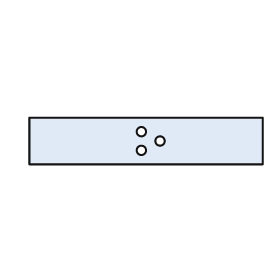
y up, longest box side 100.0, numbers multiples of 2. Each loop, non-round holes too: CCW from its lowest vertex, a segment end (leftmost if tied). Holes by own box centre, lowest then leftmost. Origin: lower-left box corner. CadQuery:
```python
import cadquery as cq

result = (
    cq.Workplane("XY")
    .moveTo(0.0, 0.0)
    .lineTo(100.0, 0.0)
    .lineTo(100.0, 20.0)
    .lineTo(0.0, 20.0)
    .close()
    .moveTo(48.0, 6.0)
    .circle(2.0)
    .moveTo(56.0, 10.0)
    .circle(2.0)
    .moveTo(48.0, 14.0)
    .circle(2.0)
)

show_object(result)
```